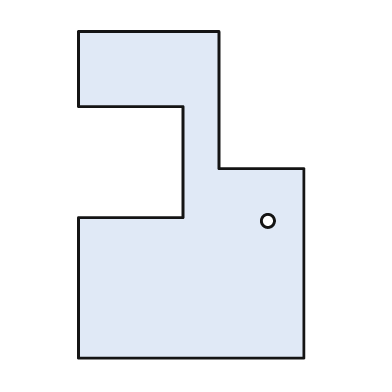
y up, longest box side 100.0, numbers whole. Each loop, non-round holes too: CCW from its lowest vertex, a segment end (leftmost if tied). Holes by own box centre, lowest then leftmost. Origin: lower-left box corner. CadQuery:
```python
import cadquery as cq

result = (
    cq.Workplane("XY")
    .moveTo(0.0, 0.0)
    .lineTo(69.0, 0.0)
    .lineTo(69.0, 58.0)
    .lineTo(43.0, 58.0)
    .lineTo(43.0, 100.0)
    .lineTo(0.0, 100.0)
    .lineTo(0.0, 77.0)
    .lineTo(32.0, 77.0)
    .lineTo(32.0, 43.0)
    .lineTo(0.0, 43.0)
    .close()
    .moveTo(58.0, 42.0)
    .circle(2.0)
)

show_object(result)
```